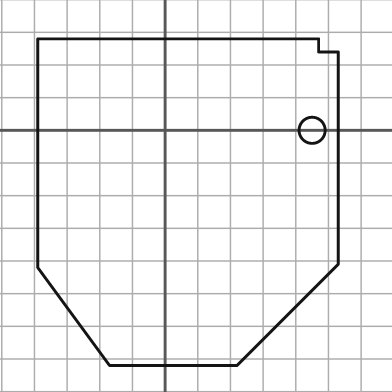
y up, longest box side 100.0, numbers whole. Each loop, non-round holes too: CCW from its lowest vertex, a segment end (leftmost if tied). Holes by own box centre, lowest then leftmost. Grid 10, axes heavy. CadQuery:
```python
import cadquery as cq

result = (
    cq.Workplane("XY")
    .moveTo(-17.0, -72.0)
    .lineTo(22.0, -72.0)
    .lineTo(53.0, -41.0)
    .lineTo(53.0, 24.0)
    .lineTo(47.0, 24.0)
    .lineTo(47.0, 28.0)
    .lineTo(-39.0, 28.0)
    .lineTo(-39.0, -42.0)
    .close()
    .moveTo(45.0, 0.0)
    .circle(4.0)
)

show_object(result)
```